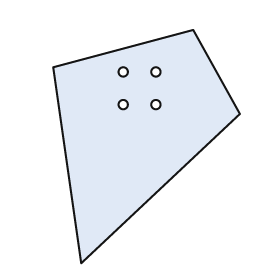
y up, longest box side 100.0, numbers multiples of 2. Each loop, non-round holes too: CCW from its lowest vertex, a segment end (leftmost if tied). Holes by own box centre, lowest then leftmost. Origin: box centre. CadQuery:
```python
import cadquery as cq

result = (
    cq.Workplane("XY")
    .moveTo(-28.0, -50.0)
    .lineTo(40.0, 14.0)
    .lineTo(20.0, 50.0)
    .lineTo(-40.0, 34.0)
    .close()
    .moveTo(-10.0, 18.0)
    .circle(2.0)
    .moveTo(4.0, 18.0)
    .circle(2.0)
    .moveTo(-10.0, 32.0)
    .circle(2.0)
    .moveTo(4.0, 32.0)
    .circle(2.0)
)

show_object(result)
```